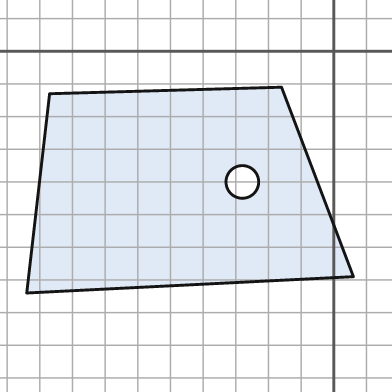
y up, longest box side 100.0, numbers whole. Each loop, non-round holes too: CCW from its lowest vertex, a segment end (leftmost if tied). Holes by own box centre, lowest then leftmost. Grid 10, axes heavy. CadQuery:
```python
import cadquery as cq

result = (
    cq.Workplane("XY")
    .moveTo(-94.0, -74.0)
    .lineTo(6.0, -69.0)
    .lineTo(-16.0, -11.0)
    .lineTo(-87.0, -13.0)
    .close()
    .moveTo(-28.0, -40.0)
    .circle(5.0)
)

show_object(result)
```